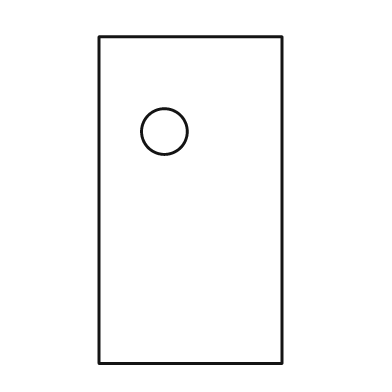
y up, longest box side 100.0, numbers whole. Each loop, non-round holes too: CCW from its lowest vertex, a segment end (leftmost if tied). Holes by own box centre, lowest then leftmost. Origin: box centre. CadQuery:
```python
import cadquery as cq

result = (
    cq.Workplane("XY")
    .moveTo(-28.0, -50.0)
    .lineTo(28.0, -50.0)
    .lineTo(28.0, 50.0)
    .lineTo(-28.0, 50.0)
    .close()
    .moveTo(-8.0, 21.0)
    .circle(7.0)
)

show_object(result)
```